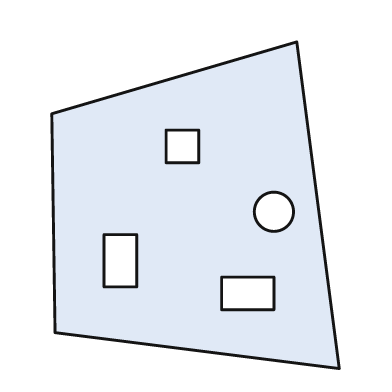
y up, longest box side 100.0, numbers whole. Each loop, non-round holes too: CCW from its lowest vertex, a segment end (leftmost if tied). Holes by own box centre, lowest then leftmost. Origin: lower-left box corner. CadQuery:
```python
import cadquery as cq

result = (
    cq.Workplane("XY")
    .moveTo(88.0, 0.0)
    .lineTo(75.0, 100.0)
    .lineTo(0.0, 78.0)
    .lineTo(1.0, 11.0)
    .close()
    .moveTo(52.0, 18.0)
    .lineTo(68.0, 18.0)
    .lineTo(68.0, 28.0)
    .lineTo(52.0, 28.0)
    .close()
    .moveTo(16.0, 25.0)
    .lineTo(26.0, 25.0)
    .lineTo(26.0, 41.0)
    .lineTo(16.0, 41.0)
    .close()
    .moveTo(68.0, 48.0)
    .circle(6.0)
    .moveTo(35.0, 63.0)
    .lineTo(45.0, 63.0)
    .lineTo(45.0, 73.0)
    .lineTo(35.0, 73.0)
    .close()
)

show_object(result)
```